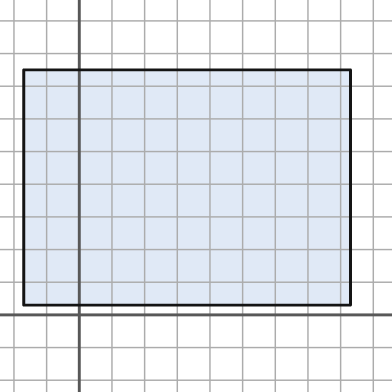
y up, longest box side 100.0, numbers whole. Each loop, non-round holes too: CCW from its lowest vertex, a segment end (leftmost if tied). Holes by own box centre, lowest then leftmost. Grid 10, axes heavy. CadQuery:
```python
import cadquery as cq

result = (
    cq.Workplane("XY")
    .moveTo(-17.0, 3.0)
    .lineTo(83.0, 3.0)
    .lineTo(83.0, 75.0)
    .lineTo(-17.0, 75.0)
    .close()
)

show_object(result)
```